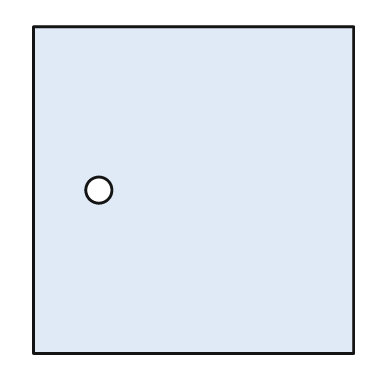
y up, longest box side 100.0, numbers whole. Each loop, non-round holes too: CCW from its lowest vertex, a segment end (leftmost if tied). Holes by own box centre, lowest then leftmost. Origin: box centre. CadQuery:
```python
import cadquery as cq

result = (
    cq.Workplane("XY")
    .moveTo(-49.0, -50.0)
    .lineTo(49.0, -50.0)
    .lineTo(49.0, 50.0)
    .lineTo(-49.0, 50.0)
    .close()
    .moveTo(-29.0, 0.0)
    .circle(4.0)
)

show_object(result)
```